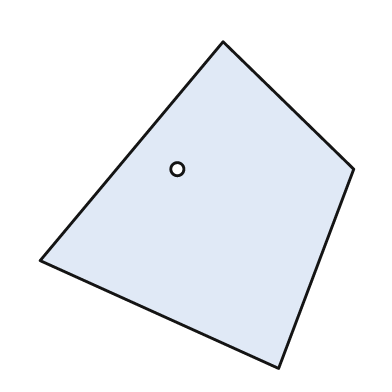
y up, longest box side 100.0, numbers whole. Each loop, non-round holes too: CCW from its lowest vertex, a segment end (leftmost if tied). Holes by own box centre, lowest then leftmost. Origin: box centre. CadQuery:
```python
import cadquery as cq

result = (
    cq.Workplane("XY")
    .moveTo(25.0, -50.0)
    .lineTo(48.0, 11.0)
    .lineTo(8.0, 50.0)
    .lineTo(-48.0, -17.0)
    .close()
    .moveTo(-6.0, 11.0)
    .circle(2.0)
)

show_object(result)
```